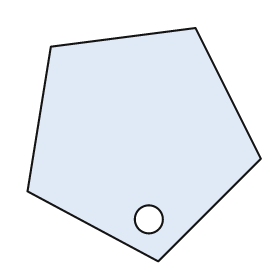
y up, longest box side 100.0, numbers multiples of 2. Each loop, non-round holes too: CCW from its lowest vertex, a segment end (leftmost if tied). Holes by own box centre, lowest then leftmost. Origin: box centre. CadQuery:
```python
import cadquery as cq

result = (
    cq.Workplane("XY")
    .moveTo(6.0, -50.0)
    .lineTo(50.0, -6.0)
    .lineTo(22.0, 50.0)
    .lineTo(-40.0, 42.0)
    .lineTo(-50.0, -20.0)
    .close()
    .moveTo(2.0, -32.0)
    .circle(6.0)
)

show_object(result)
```